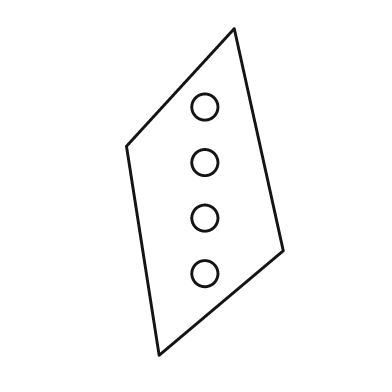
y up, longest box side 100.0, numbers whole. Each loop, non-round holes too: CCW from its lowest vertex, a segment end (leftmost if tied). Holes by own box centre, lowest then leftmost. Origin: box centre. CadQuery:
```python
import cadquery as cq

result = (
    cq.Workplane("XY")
    .moveTo(-14.0, -50.0)
    .lineTo(24.0, -18.0)
    .lineTo(9.0, 50.0)
    .lineTo(-24.0, 14.0)
    .close()
    .moveTo(0.0, -25.0)
    .circle(4.0)
    .moveTo(0.0, -8.0)
    .circle(4.0)
    .moveTo(0.0, 9.0)
    .circle(4.0)
    .moveTo(0.0, 26.0)
    .circle(4.0)
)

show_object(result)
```